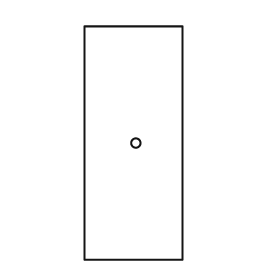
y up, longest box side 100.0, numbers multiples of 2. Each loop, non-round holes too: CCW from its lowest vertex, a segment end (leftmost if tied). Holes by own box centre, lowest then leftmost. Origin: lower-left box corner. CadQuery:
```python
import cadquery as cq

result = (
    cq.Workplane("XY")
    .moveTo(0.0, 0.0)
    .lineTo(42.0, 0.0)
    .lineTo(42.0, 100.0)
    .lineTo(0.0, 100.0)
    .close()
    .moveTo(22.0, 50.0)
    .circle(2.0)
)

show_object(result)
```